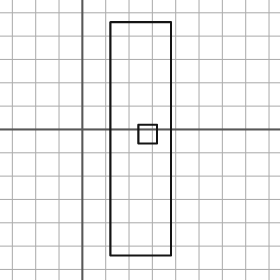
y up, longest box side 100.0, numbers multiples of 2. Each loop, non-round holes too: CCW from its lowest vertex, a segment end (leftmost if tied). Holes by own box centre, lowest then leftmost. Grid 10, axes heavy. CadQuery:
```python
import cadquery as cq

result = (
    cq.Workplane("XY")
    .moveTo(12.0, -54.0)
    .lineTo(38.0, -54.0)
    .lineTo(38.0, 46.0)
    .lineTo(12.0, 46.0)
    .close()
    .moveTo(24.0, -6.0)
    .lineTo(32.0, -6.0)
    .lineTo(32.0, 2.0)
    .lineTo(24.0, 2.0)
    .close()
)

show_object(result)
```